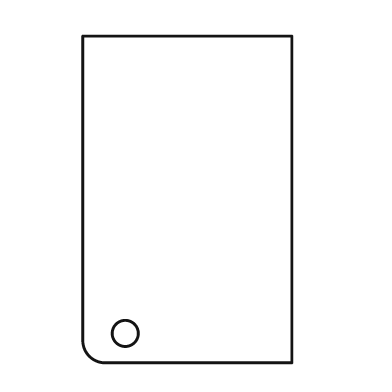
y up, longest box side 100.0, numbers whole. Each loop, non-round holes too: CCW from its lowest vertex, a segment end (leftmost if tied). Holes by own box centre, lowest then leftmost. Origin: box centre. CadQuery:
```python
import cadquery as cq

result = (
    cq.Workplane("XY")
    .moveTo(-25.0, -50.0)
    .lineTo(32.0, -50.0)
    .lineTo(32.0, 50.0)
    .lineTo(-32.0, 50.0)
    .lineTo(-32.0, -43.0)
    .threePointArc((-30.0, -48.0), (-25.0, -50.0))
    .close()
    .moveTo(-19.0, -41.0)
    .circle(4.0)
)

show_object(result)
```